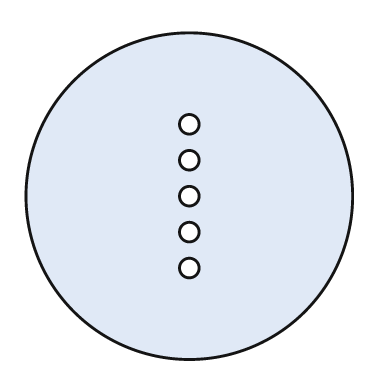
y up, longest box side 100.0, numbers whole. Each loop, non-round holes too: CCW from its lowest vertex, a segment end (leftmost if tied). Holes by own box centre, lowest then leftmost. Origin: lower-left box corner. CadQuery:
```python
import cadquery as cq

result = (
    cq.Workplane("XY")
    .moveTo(50.0, 50.0)
    .circle(50.0)
    .moveTo(50.0, 28.0)
    .circle(3.0)
    .moveTo(50.0, 39.0)
    .circle(3.0)
    .moveTo(50.0, 50.0)
    .circle(3.0)
    .moveTo(50.0, 61.0)
    .circle(3.0)
    .moveTo(50.0, 72.0)
    .circle(3.0)
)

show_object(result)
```